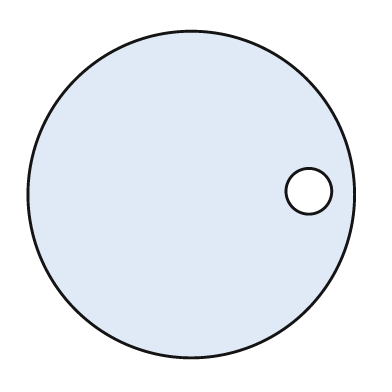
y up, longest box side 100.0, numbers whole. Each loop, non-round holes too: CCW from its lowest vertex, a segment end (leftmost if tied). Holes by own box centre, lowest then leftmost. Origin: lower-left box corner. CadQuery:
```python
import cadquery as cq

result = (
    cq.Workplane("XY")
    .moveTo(50.0, 50.0)
    .circle(50.0)
    .moveTo(86.0, 51.0)
    .circle(7.0)
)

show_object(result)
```